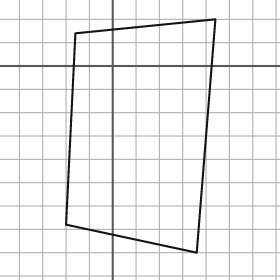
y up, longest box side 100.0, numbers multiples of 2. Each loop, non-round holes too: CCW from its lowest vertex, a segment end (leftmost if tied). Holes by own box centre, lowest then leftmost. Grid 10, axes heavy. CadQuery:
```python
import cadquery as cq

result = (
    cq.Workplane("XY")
    .moveTo(36.0, -80.0)
    .lineTo(44.0, 20.0)
    .lineTo(-16.0, 14.0)
    .lineTo(-20.0, -68.0)
    .close()
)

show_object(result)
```